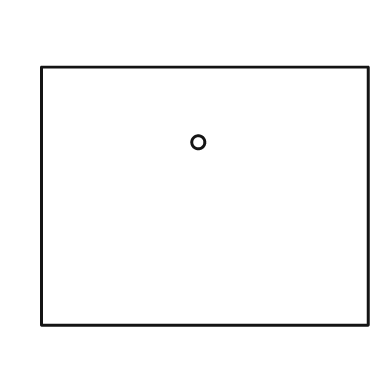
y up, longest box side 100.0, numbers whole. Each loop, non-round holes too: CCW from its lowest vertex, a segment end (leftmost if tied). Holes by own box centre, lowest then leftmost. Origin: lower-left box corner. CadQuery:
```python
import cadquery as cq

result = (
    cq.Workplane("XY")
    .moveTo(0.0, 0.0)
    .lineTo(100.0, 0.0)
    .lineTo(100.0, 79.0)
    .lineTo(0.0, 79.0)
    .close()
    .moveTo(48.0, 56.0)
    .circle(2.0)
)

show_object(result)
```